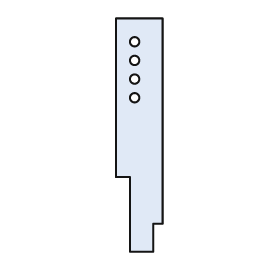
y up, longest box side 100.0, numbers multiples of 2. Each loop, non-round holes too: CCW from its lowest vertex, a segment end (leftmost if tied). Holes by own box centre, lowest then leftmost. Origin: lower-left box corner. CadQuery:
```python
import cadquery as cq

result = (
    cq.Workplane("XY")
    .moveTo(6.0, 0.0)
    .lineTo(16.0, 0.0)
    .lineTo(16.0, 12.0)
    .lineTo(20.0, 12.0)
    .lineTo(20.0, 100.0)
    .lineTo(0.0, 100.0)
    .lineTo(0.0, 32.0)
    .lineTo(6.0, 32.0)
    .close()
    .moveTo(8.0, 66.0)
    .circle(2.0)
    .moveTo(8.0, 74.0)
    .circle(2.0)
    .moveTo(8.0, 82.0)
    .circle(2.0)
    .moveTo(8.0, 90.0)
    .circle(2.0)
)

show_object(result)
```